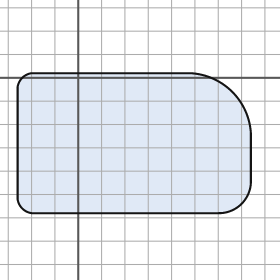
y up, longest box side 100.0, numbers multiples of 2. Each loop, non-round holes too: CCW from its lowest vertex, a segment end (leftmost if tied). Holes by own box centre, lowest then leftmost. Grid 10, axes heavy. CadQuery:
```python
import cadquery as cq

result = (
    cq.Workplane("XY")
    .moveTo(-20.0, -58.0)
    .lineTo(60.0, -58.0)
    .threePointArc((70.0, -54.0), (74.0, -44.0))
    .lineTo(74.0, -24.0)
    .threePointArc((66.0, -6.0), (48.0, 2.0))
    .lineTo(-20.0, 2.0)
    .threePointArc((-24.0, 0.0), (-26.0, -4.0))
    .lineTo(-26.0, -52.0)
    .threePointArc((-24.0, -56.0), (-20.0, -58.0))
    .close()
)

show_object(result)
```